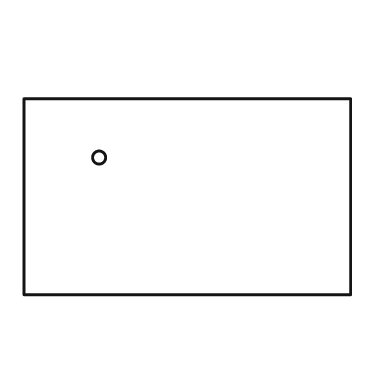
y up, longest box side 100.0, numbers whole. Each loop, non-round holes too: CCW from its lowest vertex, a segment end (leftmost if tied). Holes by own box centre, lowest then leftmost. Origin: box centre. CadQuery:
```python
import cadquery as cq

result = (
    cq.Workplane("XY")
    .moveTo(-50.0, -30.0)
    .lineTo(50.0, -30.0)
    .lineTo(50.0, 30.0)
    .lineTo(-50.0, 30.0)
    .close()
    .moveTo(-27.0, 12.0)
    .circle(2.0)
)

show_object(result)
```